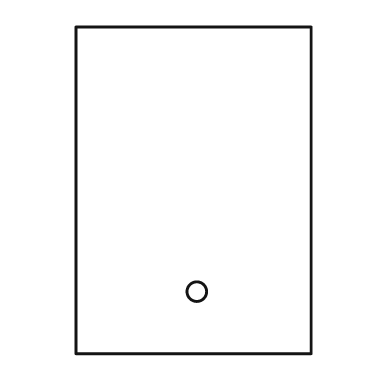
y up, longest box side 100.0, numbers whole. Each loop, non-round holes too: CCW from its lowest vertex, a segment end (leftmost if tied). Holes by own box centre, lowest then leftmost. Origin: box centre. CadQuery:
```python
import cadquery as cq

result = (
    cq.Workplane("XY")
    .moveTo(-36.0, -50.0)
    .lineTo(36.0, -50.0)
    .lineTo(36.0, 50.0)
    .lineTo(-36.0, 50.0)
    .close()
    .moveTo(1.0, -31.0)
    .circle(3.0)
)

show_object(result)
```